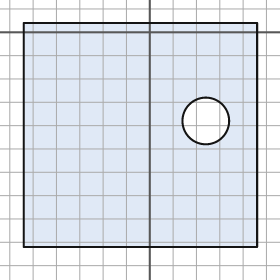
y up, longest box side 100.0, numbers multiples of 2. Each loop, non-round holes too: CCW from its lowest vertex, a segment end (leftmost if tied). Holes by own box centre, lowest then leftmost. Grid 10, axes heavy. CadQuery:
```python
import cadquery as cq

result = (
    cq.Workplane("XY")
    .moveTo(-54.0, -92.0)
    .lineTo(46.0, -92.0)
    .lineTo(46.0, 4.0)
    .lineTo(-54.0, 4.0)
    .close()
    .moveTo(24.0, -38.0)
    .circle(10.0)
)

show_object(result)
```